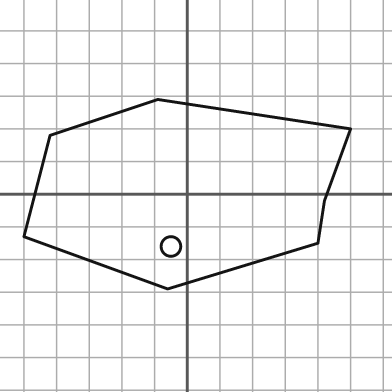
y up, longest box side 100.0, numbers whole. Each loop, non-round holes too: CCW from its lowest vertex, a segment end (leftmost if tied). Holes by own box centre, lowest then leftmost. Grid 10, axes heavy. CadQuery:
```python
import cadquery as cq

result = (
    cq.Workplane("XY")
    .moveTo(-6.0, -29.0)
    .lineTo(40.0, -15.0)
    .lineTo(42.0, -2.0)
    .lineTo(50.0, 20.0)
    .lineTo(-9.0, 29.0)
    .lineTo(-42.0, 18.0)
    .lineTo(-50.0, -13.0)
    .close()
    .moveTo(-5.0, -16.0)
    .circle(3.0)
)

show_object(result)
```